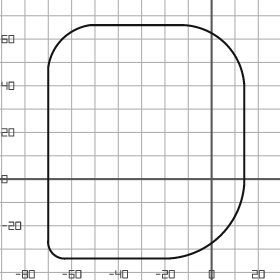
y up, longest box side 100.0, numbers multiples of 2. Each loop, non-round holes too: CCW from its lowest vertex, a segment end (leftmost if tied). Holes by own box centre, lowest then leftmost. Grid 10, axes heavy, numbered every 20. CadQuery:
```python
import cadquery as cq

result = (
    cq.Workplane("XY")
    .moveTo(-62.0, -34.0)
    .lineTo(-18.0, -34.0)
    .threePointArc((4.0, -24.0), (14.0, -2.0))
    .lineTo(14.0, 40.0)
    .threePointArc((6.0, 58.0), (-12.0, 66.0))
    .lineTo(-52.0, 66.0)
    .threePointArc((-64.0, 60.0), (-70.0, 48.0))
    .lineTo(-70.0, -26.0)
    .threePointArc((-68.0, -32.0), (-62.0, -34.0))
    .close()
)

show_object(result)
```